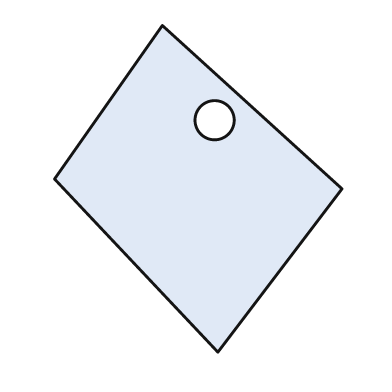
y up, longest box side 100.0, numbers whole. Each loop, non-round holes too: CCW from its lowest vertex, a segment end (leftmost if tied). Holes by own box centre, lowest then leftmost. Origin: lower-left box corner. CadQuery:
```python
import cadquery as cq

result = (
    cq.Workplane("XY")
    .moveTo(50.0, 0.0)
    .lineTo(88.0, 50.0)
    .lineTo(33.0, 100.0)
    .lineTo(0.0, 53.0)
    .close()
    .moveTo(49.0, 71.0)
    .circle(6.0)
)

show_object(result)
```